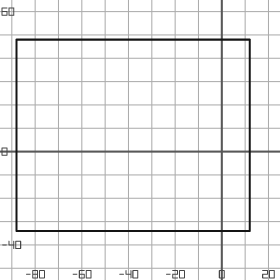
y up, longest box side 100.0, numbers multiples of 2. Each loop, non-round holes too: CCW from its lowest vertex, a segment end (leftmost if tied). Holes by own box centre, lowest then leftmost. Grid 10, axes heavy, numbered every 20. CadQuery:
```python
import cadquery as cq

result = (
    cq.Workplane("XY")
    .moveTo(-88.0, -34.0)
    .lineTo(12.0, -34.0)
    .lineTo(12.0, 48.0)
    .lineTo(-88.0, 48.0)
    .close()
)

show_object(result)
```